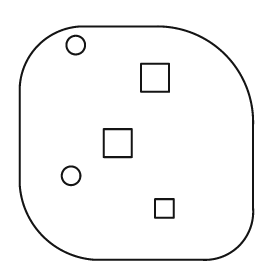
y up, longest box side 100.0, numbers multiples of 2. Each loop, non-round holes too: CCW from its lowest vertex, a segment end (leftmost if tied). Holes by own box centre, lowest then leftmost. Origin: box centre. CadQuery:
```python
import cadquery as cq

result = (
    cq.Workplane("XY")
    .moveTo(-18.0, -50.0)
    .lineTo(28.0, -50.0)
    .threePointArc((44.0, -44.0), (50.0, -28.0))
    .lineTo(50.0, 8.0)
    .threePointArc((38.0, 38.0), (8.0, 50.0))
    .lineTo(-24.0, 50.0)
    .threePointArc((-42.0, 42.0), (-50.0, 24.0))
    .lineTo(-50.0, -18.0)
    .threePointArc((-40.0, -40.0), (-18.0, -50.0))
    .close()
    .moveTo(8.0, -32.0)
    .lineTo(16.0, -32.0)
    .lineTo(16.0, -24.0)
    .lineTo(8.0, -24.0)
    .close()
    .moveTo(-28.0, -14.0)
    .circle(4.0)
    .moveTo(-14.0, -6.0)
    .lineTo(-2.0, -6.0)
    .lineTo(-2.0, 6.0)
    .lineTo(-14.0, 6.0)
    .close()
    .moveTo(2.0, 22.0)
    .lineTo(14.0, 22.0)
    .lineTo(14.0, 34.0)
    .lineTo(2.0, 34.0)
    .close()
    .moveTo(-26.0, 42.0)
    .circle(4.0)
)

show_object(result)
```